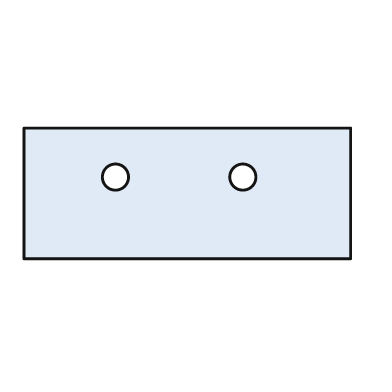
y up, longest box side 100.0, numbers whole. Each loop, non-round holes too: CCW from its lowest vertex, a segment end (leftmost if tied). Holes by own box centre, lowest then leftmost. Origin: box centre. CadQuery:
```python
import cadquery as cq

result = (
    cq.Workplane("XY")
    .moveTo(-50.0, -20.0)
    .lineTo(50.0, -20.0)
    .lineTo(50.0, 20.0)
    .lineTo(-50.0, 20.0)
    .close()
    .moveTo(-22.0, 5.0)
    .circle(4.0)
    .moveTo(17.0, 5.0)
    .circle(4.0)
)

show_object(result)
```